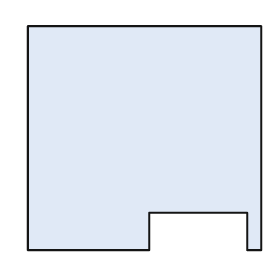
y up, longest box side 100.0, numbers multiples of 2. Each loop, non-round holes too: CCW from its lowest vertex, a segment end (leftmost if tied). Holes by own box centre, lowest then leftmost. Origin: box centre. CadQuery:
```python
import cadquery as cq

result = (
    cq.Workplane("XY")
    .moveTo(-50.0, -48.0)
    .lineTo(2.0, -48.0)
    .lineTo(2.0, -32.0)
    .lineTo(44.0, -32.0)
    .lineTo(44.0, -48.0)
    .lineTo(50.0, -48.0)
    .lineTo(50.0, 48.0)
    .lineTo(-50.0, 48.0)
    .close()
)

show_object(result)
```